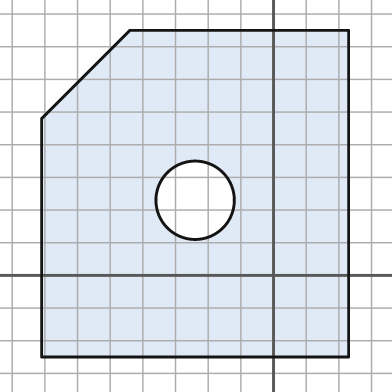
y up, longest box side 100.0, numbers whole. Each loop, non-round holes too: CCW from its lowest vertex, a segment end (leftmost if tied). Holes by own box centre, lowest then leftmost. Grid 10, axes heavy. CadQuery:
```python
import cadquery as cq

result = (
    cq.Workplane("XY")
    .moveTo(-71.0, -25.0)
    .lineTo(23.0, -25.0)
    .lineTo(23.0, 75.0)
    .lineTo(-44.0, 75.0)
    .lineTo(-71.0, 48.0)
    .close()
    .moveTo(-24.0, 23.0)
    .circle(12.0)
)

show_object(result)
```